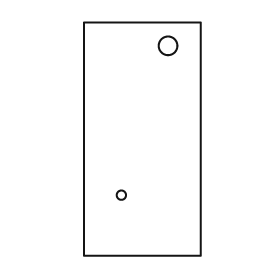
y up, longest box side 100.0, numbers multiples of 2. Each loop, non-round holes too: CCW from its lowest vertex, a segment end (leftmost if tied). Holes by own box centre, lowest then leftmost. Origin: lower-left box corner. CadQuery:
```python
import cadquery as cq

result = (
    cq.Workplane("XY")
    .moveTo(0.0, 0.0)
    .lineTo(50.0, 0.0)
    .lineTo(50.0, 100.0)
    .lineTo(0.0, 100.0)
    .close()
    .moveTo(16.0, 26.0)
    .circle(2.0)
    .moveTo(36.0, 90.0)
    .circle(4.0)
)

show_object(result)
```